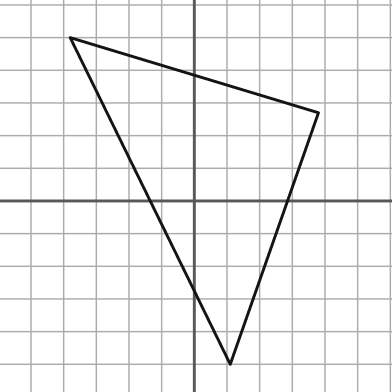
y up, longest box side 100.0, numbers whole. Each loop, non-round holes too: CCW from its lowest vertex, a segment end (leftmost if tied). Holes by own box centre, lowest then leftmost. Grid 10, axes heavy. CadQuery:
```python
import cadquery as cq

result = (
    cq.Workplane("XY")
    .moveTo(11.0, -50.0)
    .lineTo(38.0, 27.0)
    .lineTo(-38.0, 50.0)
    .close()
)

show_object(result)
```